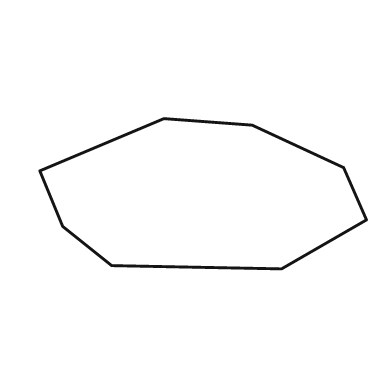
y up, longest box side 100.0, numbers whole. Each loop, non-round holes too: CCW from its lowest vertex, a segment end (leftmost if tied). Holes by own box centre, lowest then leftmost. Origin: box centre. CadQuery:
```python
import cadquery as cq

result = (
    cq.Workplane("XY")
    .moveTo(24.0, -23.0)
    .lineTo(50.0, -8.0)
    .lineTo(43.0, 8.0)
    .lineTo(15.0, 21.0)
    .lineTo(-12.0, 23.0)
    .lineTo(-50.0, 7.0)
    .lineTo(-43.0, -10.0)
    .lineTo(-28.0, -22.0)
    .close()
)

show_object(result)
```